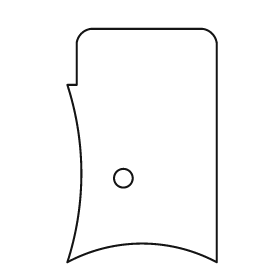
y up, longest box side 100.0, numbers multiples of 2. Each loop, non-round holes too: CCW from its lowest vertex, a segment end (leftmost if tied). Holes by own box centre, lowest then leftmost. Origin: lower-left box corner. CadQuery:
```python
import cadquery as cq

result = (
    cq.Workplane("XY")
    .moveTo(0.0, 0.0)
    .threePointArc((32.0, 8.0), (64.0, 0.0))
    .lineTo(64.0, 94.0)
    .threePointArc((62.0, 98.0), (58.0, 100.0))
    .lineTo(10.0, 100.0)
    .threePointArc((6.0, 98.0), (4.0, 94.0))
    .lineTo(4.0, 76.0)
    .lineTo(0.0, 76.0)
    .threePointArc((6.0, 38.0), (0.0, 0.0))
    .close()
    .moveTo(24.0, 36.0)
    .circle(4.0)
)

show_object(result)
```